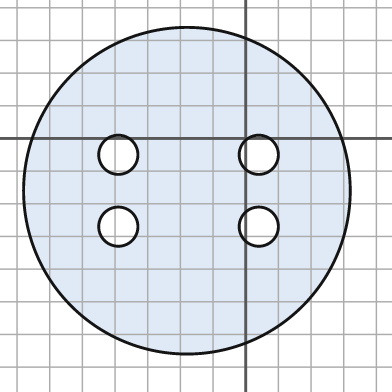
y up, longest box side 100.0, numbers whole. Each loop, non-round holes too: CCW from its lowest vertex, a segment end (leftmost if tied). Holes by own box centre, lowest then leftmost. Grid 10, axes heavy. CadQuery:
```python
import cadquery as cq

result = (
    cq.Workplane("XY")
    .moveTo(-18.0, -16.0)
    .circle(50.0)
    .moveTo(-39.0, -27.0)
    .circle(6.0)
    .moveTo(4.0, -27.0)
    .circle(6.0)
    .moveTo(-39.0, -5.0)
    .circle(6.0)
    .moveTo(4.0, -5.0)
    .circle(6.0)
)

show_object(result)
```